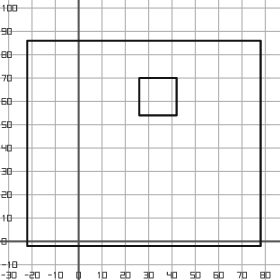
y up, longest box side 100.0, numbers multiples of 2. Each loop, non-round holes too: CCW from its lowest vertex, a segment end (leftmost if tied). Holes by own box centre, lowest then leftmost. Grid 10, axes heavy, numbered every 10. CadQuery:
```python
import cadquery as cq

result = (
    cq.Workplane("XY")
    .moveTo(-22.0, -2.0)
    .lineTo(78.0, -2.0)
    .lineTo(78.0, 86.0)
    .lineTo(-22.0, 86.0)
    .close()
    .moveTo(26.0, 54.0)
    .lineTo(42.0, 54.0)
    .lineTo(42.0, 70.0)
    .lineTo(26.0, 70.0)
    .close()
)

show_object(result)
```